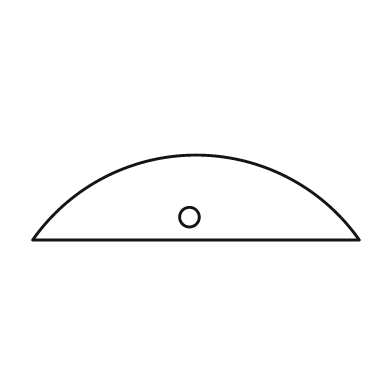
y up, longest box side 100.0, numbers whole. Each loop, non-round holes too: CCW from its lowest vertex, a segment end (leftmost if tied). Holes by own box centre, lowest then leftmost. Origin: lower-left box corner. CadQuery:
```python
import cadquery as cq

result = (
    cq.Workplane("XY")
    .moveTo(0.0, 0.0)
    .lineTo(100.0, 0.0)
    .threePointArc((50.0, 26.0), (0.0, 0.0))
    .close()
    .moveTo(48.0, 7.0)
    .circle(3.0)
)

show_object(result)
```